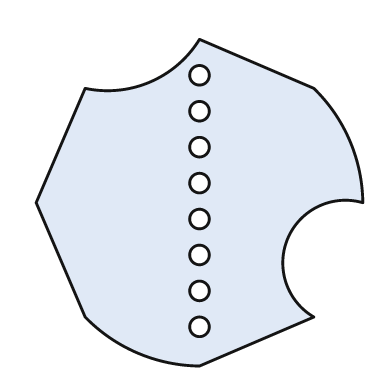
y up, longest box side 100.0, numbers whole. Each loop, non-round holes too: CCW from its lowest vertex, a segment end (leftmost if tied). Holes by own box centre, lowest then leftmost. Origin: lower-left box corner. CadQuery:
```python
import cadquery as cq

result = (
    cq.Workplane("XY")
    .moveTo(50.0, 0.0)
    .lineTo(85.0, 15.0)
    .threePointArc((77.0, 39.0), (100.0, 50.0))
    .threePointArc((96.0, 69.0), (85.0, 85.0))
    .lineTo(50.0, 100.0)
    .threePointArc((35.0, 87.0), (15.0, 85.0))
    .lineTo(0.0, 50.0)
    .lineTo(15.0, 15.0)
    .threePointArc((31.0, 4.0), (50.0, 0.0))
    .close()
    .moveTo(50.0, 12.0)
    .circle(3.0)
    .moveTo(50.0, 23.0)
    .circle(3.0)
    .moveTo(50.0, 34.0)
    .circle(3.0)
    .moveTo(50.0, 45.0)
    .circle(3.0)
    .moveTo(50.0, 56.0)
    .circle(3.0)
    .moveTo(50.0, 67.0)
    .circle(3.0)
    .moveTo(50.0, 78.0)
    .circle(3.0)
    .moveTo(50.0, 89.0)
    .circle(3.0)
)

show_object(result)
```